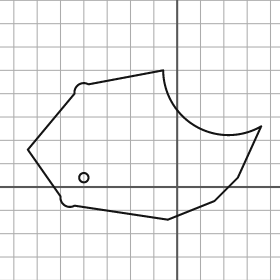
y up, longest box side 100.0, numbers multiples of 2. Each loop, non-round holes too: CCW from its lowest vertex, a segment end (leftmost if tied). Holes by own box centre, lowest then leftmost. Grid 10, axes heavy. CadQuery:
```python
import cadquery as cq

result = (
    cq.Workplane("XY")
    .moveTo(-4.0, -14.0)
    .lineTo(16.0, -6.0)
    .lineTo(26.0, 4.0)
    .lineTo(36.0, 26.0)
    .threePointArc((8.0, 26.0), (-6.0, 50.0))
    .lineTo(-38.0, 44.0)
    .threePointArc((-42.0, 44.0), (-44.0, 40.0))
    .lineTo(-64.0, 16.0)
    .lineTo(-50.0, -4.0)
    .threePointArc((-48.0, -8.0), (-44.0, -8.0))
    .close()
    .moveTo(-40.0, 4.0)
    .circle(2.0)
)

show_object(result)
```